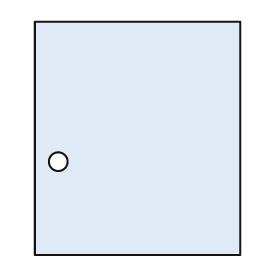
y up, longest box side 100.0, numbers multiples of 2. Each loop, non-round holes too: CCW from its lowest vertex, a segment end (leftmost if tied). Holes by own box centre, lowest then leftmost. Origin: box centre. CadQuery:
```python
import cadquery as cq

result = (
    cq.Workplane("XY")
    .moveTo(-44.0, -50.0)
    .lineTo(44.0, -50.0)
    .lineTo(44.0, 50.0)
    .lineTo(-44.0, 50.0)
    .close()
    .moveTo(-34.0, -10.0)
    .circle(4.0)
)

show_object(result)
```